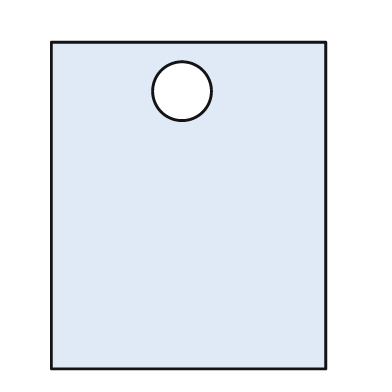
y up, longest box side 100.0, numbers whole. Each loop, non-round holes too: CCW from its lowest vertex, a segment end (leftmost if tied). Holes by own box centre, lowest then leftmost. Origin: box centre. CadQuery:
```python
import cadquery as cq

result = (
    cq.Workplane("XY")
    .moveTo(-42.0, -50.0)
    .lineTo(42.0, -50.0)
    .lineTo(42.0, 50.0)
    .lineTo(-42.0, 50.0)
    .close()
    .moveTo(-2.0, 35.0)
    .circle(9.0)
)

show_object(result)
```